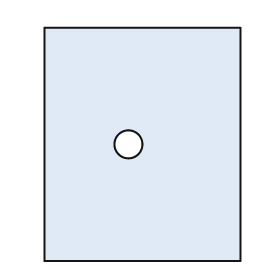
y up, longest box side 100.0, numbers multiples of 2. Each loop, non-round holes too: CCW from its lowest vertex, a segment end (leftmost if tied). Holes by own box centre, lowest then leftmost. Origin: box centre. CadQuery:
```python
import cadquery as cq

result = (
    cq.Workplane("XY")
    .moveTo(-42.0, -50.0)
    .lineTo(42.0, -50.0)
    .lineTo(42.0, 50.0)
    .lineTo(-42.0, 50.0)
    .close()
    .moveTo(-6.0, 0.0)
    .circle(6.0)
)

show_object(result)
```